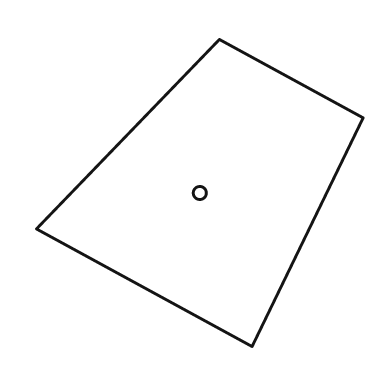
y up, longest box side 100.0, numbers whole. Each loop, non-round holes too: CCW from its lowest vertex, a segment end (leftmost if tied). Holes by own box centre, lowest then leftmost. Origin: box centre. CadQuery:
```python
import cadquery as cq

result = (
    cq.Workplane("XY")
    .moveTo(16.0, -47.0)
    .lineTo(50.0, 23.0)
    .lineTo(6.0, 47.0)
    .lineTo(-50.0, -11.0)
    .close()
    .moveTo(0.0, 0.0)
    .circle(2.0)
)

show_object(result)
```